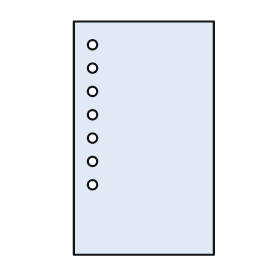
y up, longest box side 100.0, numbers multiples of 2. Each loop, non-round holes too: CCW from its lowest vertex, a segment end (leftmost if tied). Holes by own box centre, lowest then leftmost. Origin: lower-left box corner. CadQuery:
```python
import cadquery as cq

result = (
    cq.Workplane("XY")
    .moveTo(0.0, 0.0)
    .lineTo(60.0, 0.0)
    .lineTo(60.0, 100.0)
    .lineTo(0.0, 100.0)
    .close()
    .moveTo(8.0, 30.0)
    .circle(2.0)
    .moveTo(8.0, 40.0)
    .circle(2.0)
    .moveTo(8.0, 50.0)
    .circle(2.0)
    .moveTo(8.0, 60.0)
    .circle(2.0)
    .moveTo(8.0, 70.0)
    .circle(2.0)
    .moveTo(8.0, 80.0)
    .circle(2.0)
    .moveTo(8.0, 90.0)
    .circle(2.0)
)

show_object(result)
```